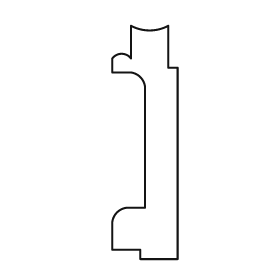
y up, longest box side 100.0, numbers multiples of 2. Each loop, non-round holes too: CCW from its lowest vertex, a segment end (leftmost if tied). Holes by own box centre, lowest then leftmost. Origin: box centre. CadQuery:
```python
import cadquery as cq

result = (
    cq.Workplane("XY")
    .moveTo(-2.0, -50.0)
    .lineTo(14.0, -50.0)
    .lineTo(14.0, 32.0)
    .lineTo(10.0, 32.0)
    .lineTo(10.0, 50.0)
    .threePointArc((2.0, 48.0), (-6.0, 50.0))
    .lineTo(-6.0, 36.0)
    .threePointArc((-10.0, 38.0), (-14.0, 36.0))
    .lineTo(-14.0, 30.0)
    .lineTo(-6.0, 30.0)
    .threePointArc((-2.0, 28.0), (0.0, 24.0))
    .lineTo(0.0, -28.0)
    .lineTo(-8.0, -28.0)
    .threePointArc((-12.0, -30.0), (-14.0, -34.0))
    .lineTo(-14.0, -46.0)
    .lineTo(-2.0, -46.0)
    .close()
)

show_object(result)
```